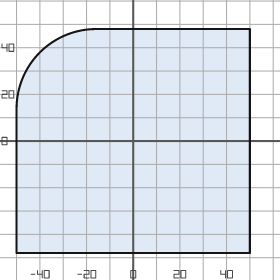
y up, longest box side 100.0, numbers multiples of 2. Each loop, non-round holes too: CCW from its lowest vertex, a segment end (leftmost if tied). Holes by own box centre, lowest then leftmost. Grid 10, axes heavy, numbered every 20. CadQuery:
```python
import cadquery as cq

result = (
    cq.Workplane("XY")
    .moveTo(-50.0, -48.0)
    .lineTo(50.0, -48.0)
    .lineTo(50.0, 48.0)
    .lineTo(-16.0, 48.0)
    .threePointArc((-40.0, 38.0), (-50.0, 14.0))
    .close()
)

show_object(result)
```